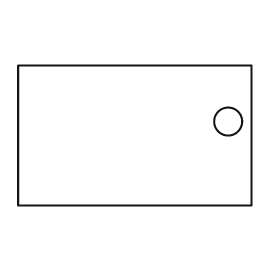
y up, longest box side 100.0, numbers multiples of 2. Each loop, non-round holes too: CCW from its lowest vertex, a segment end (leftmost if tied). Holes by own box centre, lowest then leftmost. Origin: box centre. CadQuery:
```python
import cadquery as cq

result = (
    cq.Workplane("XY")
    .moveTo(-50.0, -30.0)
    .lineTo(50.0, -30.0)
    .lineTo(50.0, 30.0)
    .lineTo(-50.0, 30.0)
    .close()
    .moveTo(40.0, 6.0)
    .circle(6.0)
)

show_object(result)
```